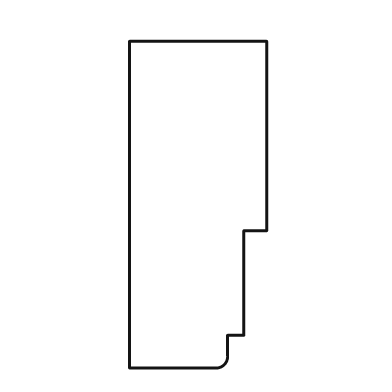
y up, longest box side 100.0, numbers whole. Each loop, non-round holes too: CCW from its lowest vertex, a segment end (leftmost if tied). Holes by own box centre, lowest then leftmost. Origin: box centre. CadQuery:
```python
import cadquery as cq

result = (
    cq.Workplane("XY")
    .moveTo(-21.0, -50.0)
    .lineTo(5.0, -50.0)
    .threePointArc((8.0, -49.0), (9.0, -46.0))
    .lineTo(9.0, -40.0)
    .lineTo(14.0, -40.0)
    .lineTo(14.0, -8.0)
    .lineTo(21.0, -8.0)
    .lineTo(21.0, 50.0)
    .lineTo(-21.0, 50.0)
    .close()
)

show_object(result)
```